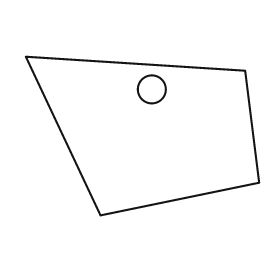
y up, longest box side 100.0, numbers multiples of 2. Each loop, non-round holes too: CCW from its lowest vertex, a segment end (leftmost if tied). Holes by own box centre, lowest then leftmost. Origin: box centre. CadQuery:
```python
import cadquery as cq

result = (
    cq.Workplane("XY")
    .moveTo(-18.0, -34.0)
    .lineTo(50.0, -20.0)
    .lineTo(44.0, 28.0)
    .lineTo(-50.0, 34.0)
    .close()
    .moveTo(4.0, 20.0)
    .circle(6.0)
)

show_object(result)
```